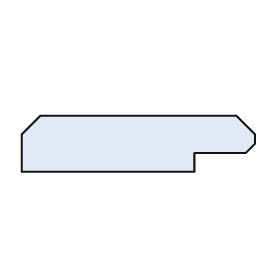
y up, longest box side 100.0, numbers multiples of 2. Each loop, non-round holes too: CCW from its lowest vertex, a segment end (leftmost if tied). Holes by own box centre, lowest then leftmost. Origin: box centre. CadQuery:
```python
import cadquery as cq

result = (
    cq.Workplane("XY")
    .moveTo(-50.0, -12.0)
    .lineTo(24.0, -12.0)
    .lineTo(24.0, -4.0)
    .lineTo(46.0, -4.0)
    .lineTo(50.0, 0.0)
    .lineTo(50.0, 4.0)
    .lineTo(42.0, 12.0)
    .lineTo(-42.0, 12.0)
    .lineTo(-50.0, 4.0)
    .close()
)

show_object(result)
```